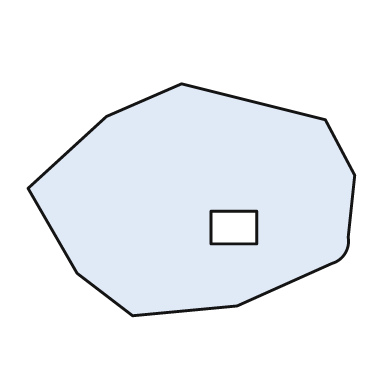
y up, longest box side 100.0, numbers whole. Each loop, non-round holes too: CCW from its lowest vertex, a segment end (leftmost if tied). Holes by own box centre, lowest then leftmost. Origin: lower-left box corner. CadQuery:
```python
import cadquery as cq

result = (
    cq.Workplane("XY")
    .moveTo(32.0, 0.0)
    .lineTo(64.0, 3.0)
    .lineTo(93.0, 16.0)
    .threePointArc((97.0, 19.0), (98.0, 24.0))
    .lineTo(100.0, 43.0)
    .lineTo(91.0, 60.0)
    .lineTo(47.0, 71.0)
    .lineTo(24.0, 61.0)
    .lineTo(0.0, 39.0)
    .lineTo(15.0, 13.0)
    .close()
    .moveTo(56.0, 22.0)
    .lineTo(70.0, 22.0)
    .lineTo(70.0, 32.0)
    .lineTo(56.0, 32.0)
    .close()
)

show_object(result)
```